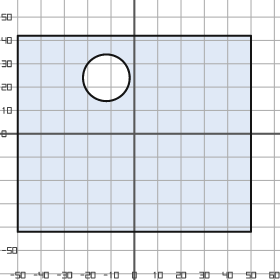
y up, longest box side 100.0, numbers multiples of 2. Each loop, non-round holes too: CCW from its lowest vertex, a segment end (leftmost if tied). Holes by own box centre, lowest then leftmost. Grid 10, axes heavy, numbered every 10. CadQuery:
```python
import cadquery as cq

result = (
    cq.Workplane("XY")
    .moveTo(-50.0, -42.0)
    .lineTo(50.0, -42.0)
    .lineTo(50.0, 42.0)
    .lineTo(-50.0, 42.0)
    .close()
    .moveTo(-12.0, 24.0)
    .circle(10.0)
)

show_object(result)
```